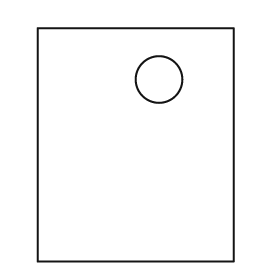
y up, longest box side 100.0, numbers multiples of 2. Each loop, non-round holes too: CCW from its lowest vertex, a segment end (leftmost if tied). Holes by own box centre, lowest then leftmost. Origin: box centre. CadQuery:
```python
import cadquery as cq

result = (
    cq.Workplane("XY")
    .moveTo(-42.0, -50.0)
    .lineTo(42.0, -50.0)
    .lineTo(42.0, 50.0)
    .lineTo(-42.0, 50.0)
    .close()
    .moveTo(10.0, 28.0)
    .circle(10.0)
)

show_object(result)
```